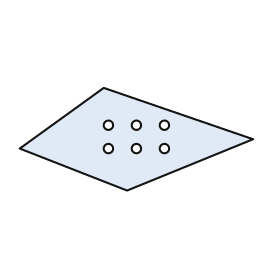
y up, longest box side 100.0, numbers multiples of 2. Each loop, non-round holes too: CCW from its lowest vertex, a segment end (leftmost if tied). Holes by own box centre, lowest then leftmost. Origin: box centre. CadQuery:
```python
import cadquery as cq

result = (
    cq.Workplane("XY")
    .moveTo(-4.0, -22.0)
    .lineTo(50.0, 0.0)
    .lineTo(-14.0, 22.0)
    .lineTo(-50.0, -4.0)
    .close()
    .moveTo(-12.0, -4.0)
    .circle(2.0)
    .moveTo(0.0, -4.0)
    .circle(2.0)
    .moveTo(12.0, -4.0)
    .circle(2.0)
    .moveTo(-12.0, 6.0)
    .circle(2.0)
    .moveTo(0.0, 6.0)
    .circle(2.0)
    .moveTo(12.0, 6.0)
    .circle(2.0)
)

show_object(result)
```